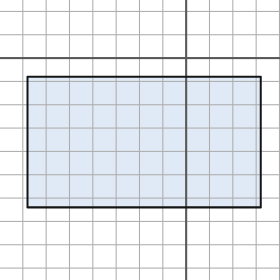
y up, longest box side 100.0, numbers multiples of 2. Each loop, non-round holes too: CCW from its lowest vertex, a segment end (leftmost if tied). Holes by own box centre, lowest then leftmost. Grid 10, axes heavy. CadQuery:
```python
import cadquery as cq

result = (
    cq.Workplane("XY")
    .moveTo(-68.0, -64.0)
    .lineTo(32.0, -64.0)
    .lineTo(32.0, -8.0)
    .lineTo(-68.0, -8.0)
    .close()
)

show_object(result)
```